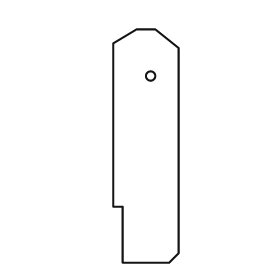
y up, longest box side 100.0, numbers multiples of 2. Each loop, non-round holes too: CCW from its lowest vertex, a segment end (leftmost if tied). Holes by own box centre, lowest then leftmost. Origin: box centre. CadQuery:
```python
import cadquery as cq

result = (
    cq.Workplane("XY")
    .moveTo(-10.0, -50.0)
    .lineTo(10.0, -50.0)
    .lineTo(14.0, -46.0)
    .lineTo(14.0, 42.0)
    .lineTo(4.0, 50.0)
    .lineTo(-4.0, 50.0)
    .lineTo(-14.0, 44.0)
    .lineTo(-14.0, -26.0)
    .lineTo(-10.0, -26.0)
    .close()
    .moveTo(2.0, 30.0)
    .circle(2.0)
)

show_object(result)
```